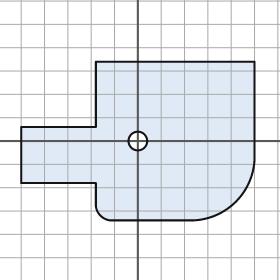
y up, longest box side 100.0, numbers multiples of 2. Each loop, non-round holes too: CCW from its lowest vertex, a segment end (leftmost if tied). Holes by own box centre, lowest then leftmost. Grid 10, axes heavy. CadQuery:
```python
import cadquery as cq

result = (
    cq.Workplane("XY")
    .moveTo(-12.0, -34.0)
    .lineTo(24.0, -34.0)
    .threePointArc((42.0, -26.0), (50.0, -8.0))
    .lineTo(50.0, 34.0)
    .lineTo(-18.0, 34.0)
    .lineTo(-18.0, 6.0)
    .lineTo(-50.0, 6.0)
    .lineTo(-50.0, -18.0)
    .lineTo(-18.0, -18.0)
    .lineTo(-18.0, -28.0)
    .threePointArc((-16.0, -32.0), (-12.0, -34.0))
    .close()
    .moveTo(0.0, 0.0)
    .circle(4.0)
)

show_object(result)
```